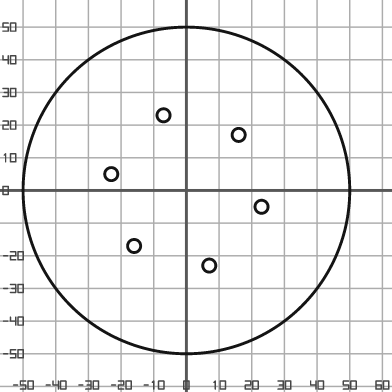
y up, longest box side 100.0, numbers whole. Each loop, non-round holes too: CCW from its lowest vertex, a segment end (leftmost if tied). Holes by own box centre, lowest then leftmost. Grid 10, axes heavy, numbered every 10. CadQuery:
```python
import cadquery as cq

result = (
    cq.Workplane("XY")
    .moveTo(0.0, 0.0)
    .circle(50.0)
    .moveTo(7.0, -23.0)
    .circle(2.0)
    .moveTo(-16.0, -17.0)
    .circle(2.0)
    .moveTo(23.0, -5.0)
    .circle(2.0)
    .moveTo(-23.0, 5.0)
    .circle(2.0)
    .moveTo(16.0, 17.0)
    .circle(2.0)
    .moveTo(-7.0, 23.0)
    .circle(2.0)
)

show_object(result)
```